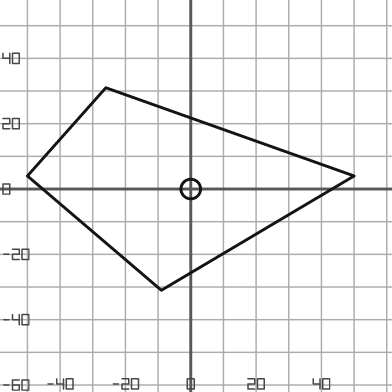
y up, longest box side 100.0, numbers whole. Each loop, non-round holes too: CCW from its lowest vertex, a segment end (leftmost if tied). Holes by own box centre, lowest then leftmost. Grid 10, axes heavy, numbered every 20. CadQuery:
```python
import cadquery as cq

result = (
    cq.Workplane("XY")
    .moveTo(-9.0, -31.0)
    .lineTo(50.0, 4.0)
    .lineTo(-26.0, 31.0)
    .lineTo(-50.0, 4.0)
    .close()
    .moveTo(0.0, 0.0)
    .circle(3.0)
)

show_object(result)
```